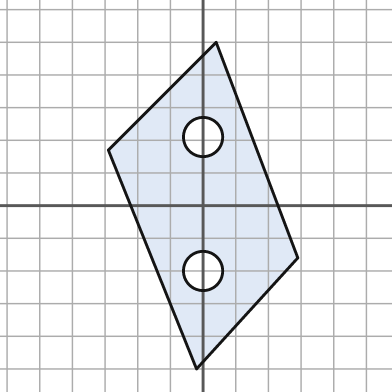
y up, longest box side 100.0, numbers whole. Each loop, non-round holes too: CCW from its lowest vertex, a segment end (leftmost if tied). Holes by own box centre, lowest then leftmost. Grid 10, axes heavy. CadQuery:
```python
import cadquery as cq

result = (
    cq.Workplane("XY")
    .moveTo(-2.0, -50.0)
    .lineTo(29.0, -16.0)
    .lineTo(4.0, 50.0)
    .lineTo(-29.0, 17.0)
    .close()
    .moveTo(0.0, -20.0)
    .circle(6.0)
    .moveTo(0.0, 21.0)
    .circle(6.0)
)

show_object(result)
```